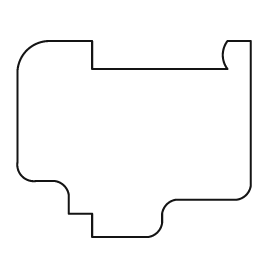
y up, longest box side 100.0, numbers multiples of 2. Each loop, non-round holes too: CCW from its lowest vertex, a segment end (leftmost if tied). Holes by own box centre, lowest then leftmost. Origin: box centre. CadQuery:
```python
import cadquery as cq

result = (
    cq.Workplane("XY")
    .moveTo(-18.0, -42.0)
    .lineTo(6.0, -42.0)
    .threePointArc((10.0, -40.0), (12.0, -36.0))
    .lineTo(12.0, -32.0)
    .threePointArc((14.0, -28.0), (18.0, -26.0))
    .lineTo(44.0, -26.0)
    .threePointArc((48.0, -24.0), (50.0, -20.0))
    .lineTo(50.0, 42.0)
    .lineTo(40.0, 42.0)
    .threePointArc((38.0, 36.0), (40.0, 30.0))
    .lineTo(-18.0, 30.0)
    .lineTo(-18.0, 42.0)
    .lineTo(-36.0, 42.0)
    .threePointArc((-46.0, 38.0), (-50.0, 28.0))
    .lineTo(-50.0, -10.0)
    .threePointArc((-48.0, -16.0), (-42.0, -18.0))
    .lineTo(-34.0, -18.0)
    .threePointArc((-30.0, -20.0), (-28.0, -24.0))
    .lineTo(-28.0, -32.0)
    .lineTo(-18.0, -32.0)
    .close()
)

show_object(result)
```